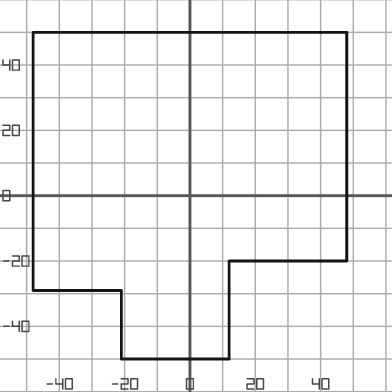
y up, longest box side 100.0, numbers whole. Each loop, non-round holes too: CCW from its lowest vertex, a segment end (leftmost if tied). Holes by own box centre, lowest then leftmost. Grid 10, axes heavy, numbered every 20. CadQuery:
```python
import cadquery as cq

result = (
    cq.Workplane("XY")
    .moveTo(-21.0, -50.0)
    .lineTo(12.0, -50.0)
    .lineTo(12.0, -20.0)
    .lineTo(48.0, -20.0)
    .lineTo(48.0, 50.0)
    .lineTo(-48.0, 50.0)
    .lineTo(-48.0, -29.0)
    .lineTo(-21.0, -29.0)
    .close()
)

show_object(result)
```